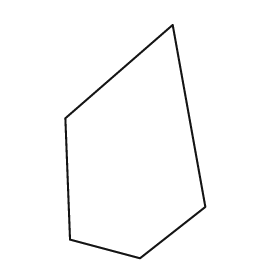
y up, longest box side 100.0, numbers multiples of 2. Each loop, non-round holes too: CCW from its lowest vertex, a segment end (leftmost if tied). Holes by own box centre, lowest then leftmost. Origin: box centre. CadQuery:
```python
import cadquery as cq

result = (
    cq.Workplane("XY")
    .moveTo(2.0, -50.0)
    .lineTo(30.0, -28.0)
    .lineTo(16.0, 50.0)
    .lineTo(-30.0, 10.0)
    .lineTo(-28.0, -42.0)
    .close()
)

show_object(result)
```